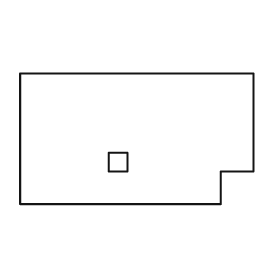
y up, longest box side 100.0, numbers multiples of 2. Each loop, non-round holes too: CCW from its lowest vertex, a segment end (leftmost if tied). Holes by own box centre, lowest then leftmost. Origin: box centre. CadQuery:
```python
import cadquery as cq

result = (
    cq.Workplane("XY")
    .moveTo(-50.0, -28.0)
    .lineTo(36.0, -28.0)
    .lineTo(36.0, -14.0)
    .lineTo(50.0, -14.0)
    .lineTo(50.0, 28.0)
    .lineTo(-50.0, 28.0)
    .close()
    .moveTo(-12.0, -14.0)
    .lineTo(-4.0, -14.0)
    .lineTo(-4.0, -6.0)
    .lineTo(-12.0, -6.0)
    .close()
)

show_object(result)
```